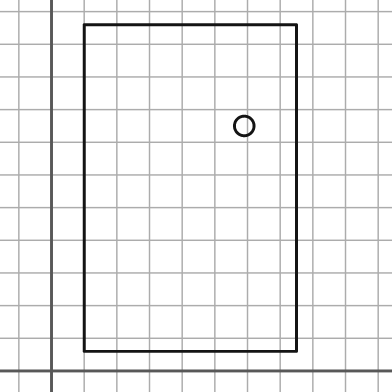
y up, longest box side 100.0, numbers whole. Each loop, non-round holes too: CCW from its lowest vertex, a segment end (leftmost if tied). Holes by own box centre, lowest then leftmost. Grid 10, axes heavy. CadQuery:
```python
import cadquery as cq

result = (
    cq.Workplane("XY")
    .moveTo(10.0, 6.0)
    .lineTo(75.0, 6.0)
    .lineTo(75.0, 106.0)
    .lineTo(10.0, 106.0)
    .close()
    .moveTo(59.0, 75.0)
    .circle(3.0)
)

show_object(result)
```